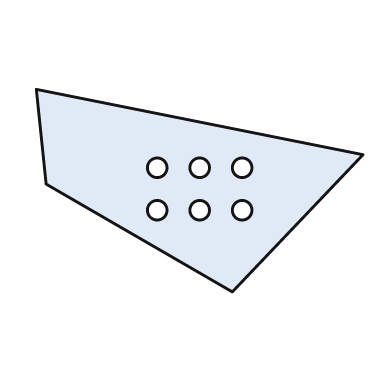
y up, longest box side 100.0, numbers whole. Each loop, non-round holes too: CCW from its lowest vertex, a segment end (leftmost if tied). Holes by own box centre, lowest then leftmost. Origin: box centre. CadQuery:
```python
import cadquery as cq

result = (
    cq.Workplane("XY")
    .moveTo(10.0, -31.0)
    .lineTo(50.0, 11.0)
    .lineTo(-50.0, 31.0)
    .lineTo(-47.0, 2.0)
    .close()
    .moveTo(-13.0, -6.0)
    .circle(3.0)
    .moveTo(0.0, -6.0)
    .circle(3.0)
    .moveTo(13.0, -6.0)
    .circle(3.0)
    .moveTo(-13.0, 7.0)
    .circle(3.0)
    .moveTo(0.0, 7.0)
    .circle(3.0)
    .moveTo(13.0, 7.0)
    .circle(3.0)
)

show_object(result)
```